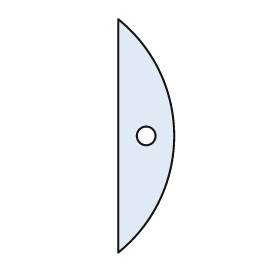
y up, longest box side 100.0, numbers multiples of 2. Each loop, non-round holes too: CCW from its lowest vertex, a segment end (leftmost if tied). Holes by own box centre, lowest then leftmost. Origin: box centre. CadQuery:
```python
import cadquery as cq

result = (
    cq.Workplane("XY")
    .moveTo(-12.0, -50.0)
    .threePointArc((12.0, 0.0), (-12.0, 50.0))
    .close()
    .moveTo(0.0, 0.0)
    .circle(4.0)
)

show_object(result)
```